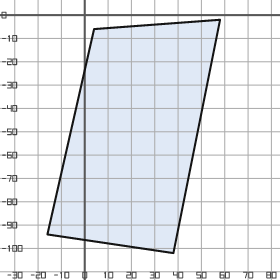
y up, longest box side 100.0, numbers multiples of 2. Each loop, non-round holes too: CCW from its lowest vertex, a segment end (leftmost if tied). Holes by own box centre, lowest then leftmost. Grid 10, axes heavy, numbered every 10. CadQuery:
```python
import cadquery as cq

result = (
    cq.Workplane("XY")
    .moveTo(38.0, -102.0)
    .lineTo(58.0, -2.0)
    .lineTo(4.0, -6.0)
    .lineTo(-16.0, -94.0)
    .close()
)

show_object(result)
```